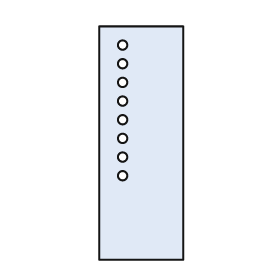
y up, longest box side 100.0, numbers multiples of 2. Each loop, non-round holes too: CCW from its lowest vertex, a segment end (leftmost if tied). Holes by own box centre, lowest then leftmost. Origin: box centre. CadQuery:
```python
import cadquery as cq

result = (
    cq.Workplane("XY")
    .moveTo(-18.0, -50.0)
    .lineTo(18.0, -50.0)
    .lineTo(18.0, 50.0)
    .lineTo(-18.0, 50.0)
    .close()
    .moveTo(-8.0, -14.0)
    .circle(2.0)
    .moveTo(-8.0, -6.0)
    .circle(2.0)
    .moveTo(-8.0, 2.0)
    .circle(2.0)
    .moveTo(-8.0, 10.0)
    .circle(2.0)
    .moveTo(-8.0, 18.0)
    .circle(2.0)
    .moveTo(-8.0, 26.0)
    .circle(2.0)
    .moveTo(-8.0, 34.0)
    .circle(2.0)
    .moveTo(-8.0, 42.0)
    .circle(2.0)
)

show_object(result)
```